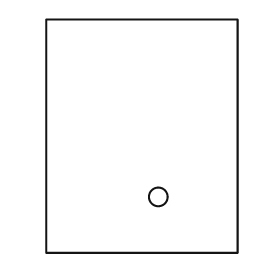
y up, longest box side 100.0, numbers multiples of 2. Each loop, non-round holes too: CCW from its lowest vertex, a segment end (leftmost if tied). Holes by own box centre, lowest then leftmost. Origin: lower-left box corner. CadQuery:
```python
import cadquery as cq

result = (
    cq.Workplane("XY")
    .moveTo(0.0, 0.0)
    .lineTo(82.0, 0.0)
    .lineTo(82.0, 100.0)
    .lineTo(0.0, 100.0)
    .close()
    .moveTo(48.0, 24.0)
    .circle(4.0)
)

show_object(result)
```